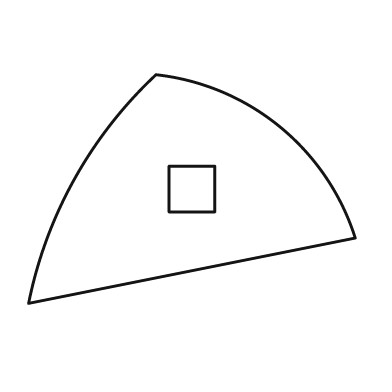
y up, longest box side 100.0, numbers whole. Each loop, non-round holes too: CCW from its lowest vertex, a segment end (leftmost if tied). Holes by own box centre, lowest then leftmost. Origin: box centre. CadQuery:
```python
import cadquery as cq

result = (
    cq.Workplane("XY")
    .moveTo(-50.0, -35.0)
    .lineTo(50.0, -15.0)
    .threePointArc((27.0, 19.0), (-11.0, 35.0))
    .threePointArc((-36.0, 3.0), (-50.0, -35.0))
    .close()
    .moveTo(-7.0, -7.0)
    .lineTo(7.0, -7.0)
    .lineTo(7.0, 7.0)
    .lineTo(-7.0, 7.0)
    .close()
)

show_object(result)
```